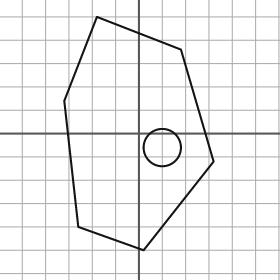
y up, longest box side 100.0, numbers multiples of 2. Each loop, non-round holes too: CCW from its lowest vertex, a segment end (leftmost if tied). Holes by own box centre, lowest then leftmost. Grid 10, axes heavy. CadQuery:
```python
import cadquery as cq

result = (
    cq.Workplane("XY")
    .moveTo(2.0, -50.0)
    .lineTo(32.0, -12.0)
    .lineTo(18.0, 36.0)
    .lineTo(-18.0, 50.0)
    .lineTo(-32.0, 14.0)
    .lineTo(-26.0, -40.0)
    .close()
    .moveTo(10.0, -6.0)
    .circle(8.0)
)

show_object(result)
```